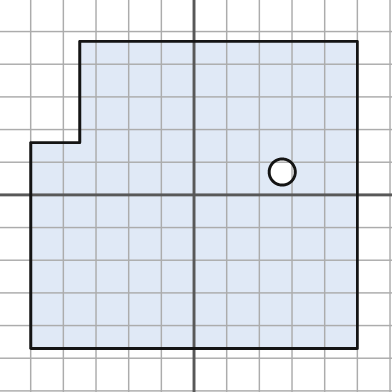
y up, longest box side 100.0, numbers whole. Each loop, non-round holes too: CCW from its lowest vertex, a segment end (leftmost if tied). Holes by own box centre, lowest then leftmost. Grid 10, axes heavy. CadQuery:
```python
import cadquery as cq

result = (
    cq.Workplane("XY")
    .moveTo(-50.0, -47.0)
    .lineTo(50.0, -47.0)
    .lineTo(50.0, 47.0)
    .lineTo(-35.0, 47.0)
    .lineTo(-35.0, 16.0)
    .lineTo(-50.0, 16.0)
    .close()
    .moveTo(27.0, 7.0)
    .circle(4.0)
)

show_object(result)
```